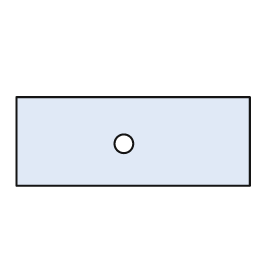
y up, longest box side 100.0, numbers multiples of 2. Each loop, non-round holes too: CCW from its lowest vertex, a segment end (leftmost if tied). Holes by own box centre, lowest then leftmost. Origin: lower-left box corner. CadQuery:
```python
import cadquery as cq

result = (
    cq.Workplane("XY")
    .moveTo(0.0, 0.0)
    .lineTo(100.0, 0.0)
    .lineTo(100.0, 38.0)
    .lineTo(0.0, 38.0)
    .close()
    .moveTo(46.0, 18.0)
    .circle(4.0)
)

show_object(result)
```